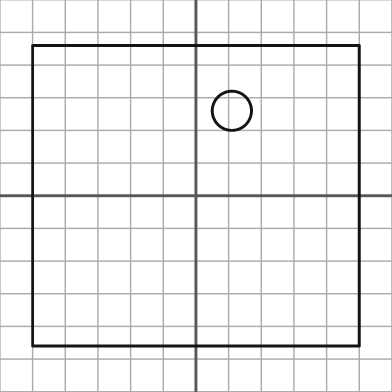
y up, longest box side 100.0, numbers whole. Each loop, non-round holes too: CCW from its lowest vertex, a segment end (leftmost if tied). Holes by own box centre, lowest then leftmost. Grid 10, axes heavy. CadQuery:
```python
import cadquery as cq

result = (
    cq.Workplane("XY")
    .moveTo(-50.0, -46.0)
    .lineTo(50.0, -46.0)
    .lineTo(50.0, 46.0)
    .lineTo(-50.0, 46.0)
    .close()
    .moveTo(11.0, 26.0)
    .circle(6.0)
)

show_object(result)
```